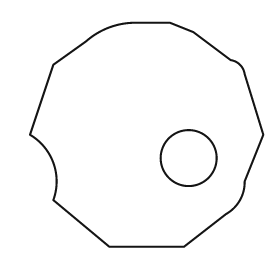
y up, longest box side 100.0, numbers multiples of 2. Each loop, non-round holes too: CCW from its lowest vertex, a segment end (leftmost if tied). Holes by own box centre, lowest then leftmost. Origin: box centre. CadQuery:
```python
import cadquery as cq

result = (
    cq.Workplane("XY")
    .moveTo(-16.0, -48.0)
    .lineTo(16.0, -48.0)
    .lineTo(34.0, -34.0)
    .threePointArc((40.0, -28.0), (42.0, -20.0))
    .lineTo(50.0, 0.0)
    .lineTo(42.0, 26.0)
    .threePointArc((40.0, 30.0), (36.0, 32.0))
    .lineTo(20.0, 44.0)
    .lineTo(10.0, 48.0)
    .lineTo(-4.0, 48.0)
    .threePointArc((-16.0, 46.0), (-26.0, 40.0))
    .lineTo(-40.0, 30.0)
    .lineTo(-50.0, 0.0)
    .threePointArc((-40.0, -12.0), (-40.0, -28.0))
    .close()
    .moveTo(18.0, -10.0)
    .circle(12.0)
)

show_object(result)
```